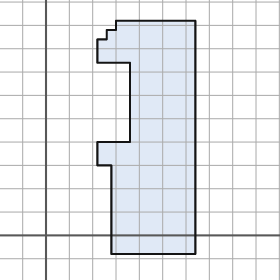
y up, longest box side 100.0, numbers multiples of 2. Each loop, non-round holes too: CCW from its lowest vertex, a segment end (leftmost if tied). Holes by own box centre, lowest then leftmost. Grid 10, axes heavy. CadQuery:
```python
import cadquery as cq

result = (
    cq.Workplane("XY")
    .moveTo(28.0, -8.0)
    .lineTo(64.0, -8.0)
    .lineTo(64.0, 92.0)
    .lineTo(30.0, 92.0)
    .lineTo(30.0, 88.0)
    .lineTo(26.0, 88.0)
    .lineTo(26.0, 84.0)
    .lineTo(22.0, 84.0)
    .lineTo(22.0, 74.0)
    .lineTo(36.0, 74.0)
    .lineTo(36.0, 40.0)
    .lineTo(22.0, 40.0)
    .lineTo(22.0, 30.0)
    .lineTo(28.0, 30.0)
    .close()
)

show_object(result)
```